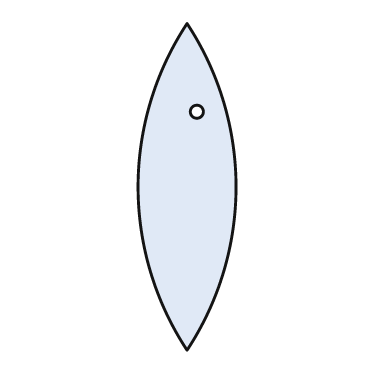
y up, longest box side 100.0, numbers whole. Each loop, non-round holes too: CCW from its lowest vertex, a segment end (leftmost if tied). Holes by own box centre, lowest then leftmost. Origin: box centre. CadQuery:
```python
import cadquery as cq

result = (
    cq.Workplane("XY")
    .moveTo(0.0, -50.0)
    .threePointArc((15.0, 0.0), (0.0, 50.0))
    .threePointArc((-15.0, 0.0), (0.0, -50.0))
    .close()
    .moveTo(3.0, 23.0)
    .circle(2.0)
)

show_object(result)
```